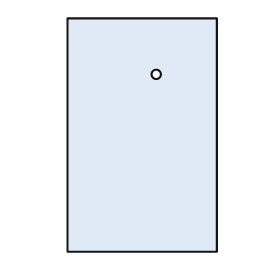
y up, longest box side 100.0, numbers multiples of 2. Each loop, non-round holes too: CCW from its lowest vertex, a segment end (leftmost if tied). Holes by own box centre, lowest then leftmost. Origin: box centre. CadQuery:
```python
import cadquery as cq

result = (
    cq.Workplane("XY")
    .moveTo(-32.0, -50.0)
    .lineTo(32.0, -50.0)
    .lineTo(32.0, 50.0)
    .lineTo(-32.0, 50.0)
    .close()
    .moveTo(6.0, 26.0)
    .circle(2.0)
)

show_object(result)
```